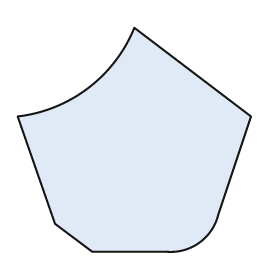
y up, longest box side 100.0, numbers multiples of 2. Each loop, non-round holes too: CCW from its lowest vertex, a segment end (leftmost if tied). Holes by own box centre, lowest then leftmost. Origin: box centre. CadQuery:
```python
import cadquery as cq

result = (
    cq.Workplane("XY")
    .moveTo(-18.0, -48.0)
    .lineTo(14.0, -48.0)
    .threePointArc((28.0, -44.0), (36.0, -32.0))
    .lineTo(50.0, 10.0)
    .lineTo(0.0, 48.0)
    .threePointArc((-20.0, 22.0), (-50.0, 10.0))
    .lineTo(-34.0, -36.0)
    .close()
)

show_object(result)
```